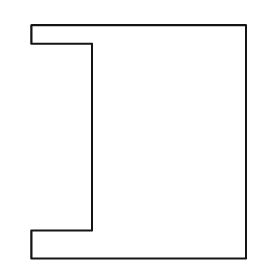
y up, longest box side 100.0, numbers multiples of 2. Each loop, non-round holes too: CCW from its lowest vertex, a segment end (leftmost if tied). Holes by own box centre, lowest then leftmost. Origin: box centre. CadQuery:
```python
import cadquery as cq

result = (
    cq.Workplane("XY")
    .moveTo(-46.0, -50.0)
    .lineTo(46.0, -50.0)
    .lineTo(46.0, 50.0)
    .lineTo(-46.0, 50.0)
    .lineTo(-46.0, 42.0)
    .lineTo(-20.0, 42.0)
    .lineTo(-20.0, -38.0)
    .lineTo(-46.0, -38.0)
    .close()
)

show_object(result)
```